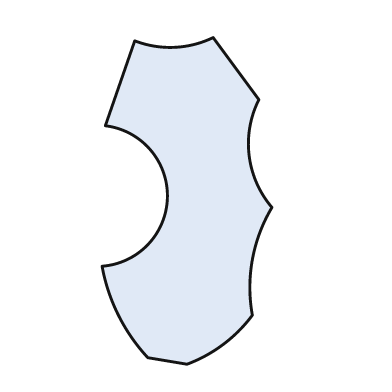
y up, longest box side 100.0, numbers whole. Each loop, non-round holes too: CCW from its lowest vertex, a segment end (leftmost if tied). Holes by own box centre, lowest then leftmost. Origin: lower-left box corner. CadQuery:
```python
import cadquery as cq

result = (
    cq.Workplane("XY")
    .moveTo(26.0, 0.0)
    .threePointArc((37.0, 6.0), (46.0, 15.0))
    .threePointArc((46.0, 32.0), (52.0, 48.0))
    .threePointArc((45.0, 64.0), (48.0, 81.0))
    .lineTo(34.0, 100.0)
    .threePointArc((22.0, 97.0), (10.0, 99.0))
    .lineTo(1.0, 73.0)
    .threePointArc((20.0, 51.0), (0.0, 30.0))
    .threePointArc((5.0, 15.0), (14.0, 2.0))
    .close()
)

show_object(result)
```